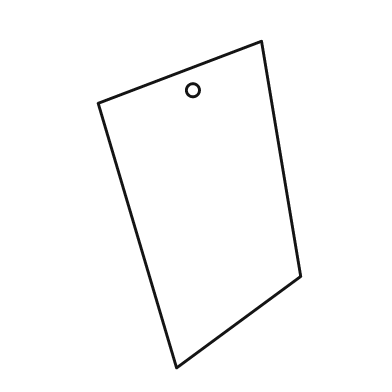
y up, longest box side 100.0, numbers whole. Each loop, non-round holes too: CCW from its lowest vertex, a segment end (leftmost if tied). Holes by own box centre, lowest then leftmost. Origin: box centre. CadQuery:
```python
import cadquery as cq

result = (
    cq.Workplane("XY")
    .moveTo(-7.0, -50.0)
    .lineTo(31.0, -22.0)
    .lineTo(19.0, 50.0)
    .lineTo(-31.0, 31.0)
    .close()
    .moveTo(-2.0, 35.0)
    .circle(2.0)
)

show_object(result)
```